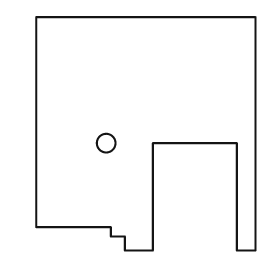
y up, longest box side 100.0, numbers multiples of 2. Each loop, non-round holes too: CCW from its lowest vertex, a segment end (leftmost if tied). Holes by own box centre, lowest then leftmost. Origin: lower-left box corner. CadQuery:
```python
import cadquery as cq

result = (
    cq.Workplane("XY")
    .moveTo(38.0, 0.0)
    .lineTo(50.0, 0.0)
    .lineTo(50.0, 46.0)
    .lineTo(86.0, 46.0)
    .lineTo(86.0, 0.0)
    .lineTo(94.0, 0.0)
    .lineTo(94.0, 100.0)
    .lineTo(0.0, 100.0)
    .lineTo(0.0, 10.0)
    .lineTo(32.0, 10.0)
    .lineTo(32.0, 6.0)
    .lineTo(38.0, 6.0)
    .close()
    .moveTo(30.0, 46.0)
    .circle(4.0)
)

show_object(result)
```